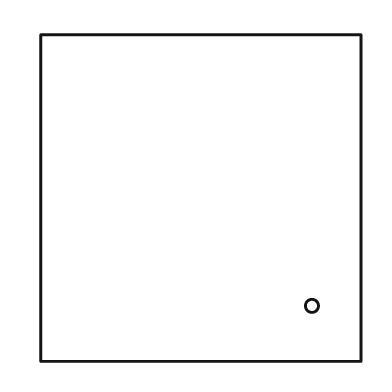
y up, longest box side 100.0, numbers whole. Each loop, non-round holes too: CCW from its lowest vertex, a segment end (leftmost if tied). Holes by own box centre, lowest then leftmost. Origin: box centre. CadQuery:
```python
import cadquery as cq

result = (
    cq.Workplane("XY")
    .moveTo(-49.0, -50.0)
    .lineTo(49.0, -50.0)
    .lineTo(49.0, 50.0)
    .lineTo(-49.0, 50.0)
    .close()
    .moveTo(34.0, -33.0)
    .circle(2.0)
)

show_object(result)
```